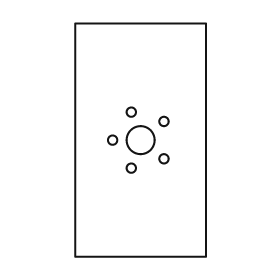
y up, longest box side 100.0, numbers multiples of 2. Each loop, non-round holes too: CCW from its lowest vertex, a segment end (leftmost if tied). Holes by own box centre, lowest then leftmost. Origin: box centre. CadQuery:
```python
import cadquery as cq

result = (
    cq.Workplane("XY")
    .moveTo(-28.0, -50.0)
    .lineTo(28.0, -50.0)
    .lineTo(28.0, 50.0)
    .lineTo(-28.0, 50.0)
    .close()
    .moveTo(-4.0, -12.0)
    .circle(2.0)
    .moveTo(10.0, -8.0)
    .circle(2.0)
    .moveTo(-12.0, 0.0)
    .circle(2.0)
    .moveTo(0.0, 0.0)
    .circle(6.0)
    .moveTo(10.0, 8.0)
    .circle(2.0)
    .moveTo(-4.0, 12.0)
    .circle(2.0)
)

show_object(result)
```